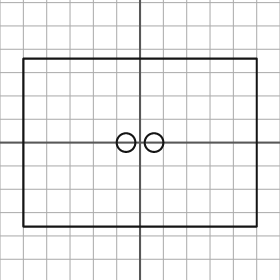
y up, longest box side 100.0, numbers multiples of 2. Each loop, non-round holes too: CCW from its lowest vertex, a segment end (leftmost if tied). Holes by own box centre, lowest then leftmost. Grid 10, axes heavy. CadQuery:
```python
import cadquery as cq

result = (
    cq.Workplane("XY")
    .moveTo(-50.0, -36.0)
    .lineTo(50.0, -36.0)
    .lineTo(50.0, 36.0)
    .lineTo(-50.0, 36.0)
    .close()
    .moveTo(-6.0, 0.0)
    .circle(4.0)
    .moveTo(6.0, 0.0)
    .circle(4.0)
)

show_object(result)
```